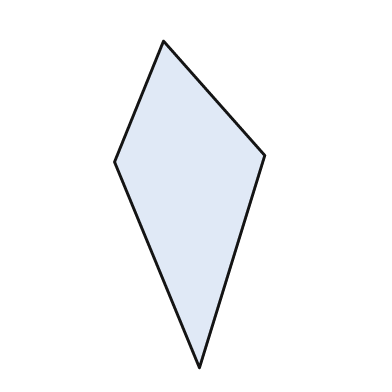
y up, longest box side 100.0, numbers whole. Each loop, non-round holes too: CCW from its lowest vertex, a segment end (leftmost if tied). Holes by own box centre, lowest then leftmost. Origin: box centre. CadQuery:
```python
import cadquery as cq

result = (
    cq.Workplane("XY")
    .moveTo(3.0, -50.0)
    .lineTo(23.0, 15.0)
    .lineTo(-8.0, 50.0)
    .lineTo(-23.0, 13.0)
    .close()
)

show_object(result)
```